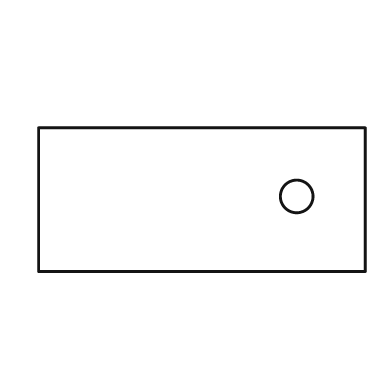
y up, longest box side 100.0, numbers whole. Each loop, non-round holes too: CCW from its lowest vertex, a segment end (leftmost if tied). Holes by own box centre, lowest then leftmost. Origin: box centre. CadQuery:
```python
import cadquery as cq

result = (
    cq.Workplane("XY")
    .moveTo(-50.0, -22.0)
    .lineTo(50.0, -22.0)
    .lineTo(50.0, 22.0)
    .lineTo(-50.0, 22.0)
    .close()
    .moveTo(29.0, 1.0)
    .circle(5.0)
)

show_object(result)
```